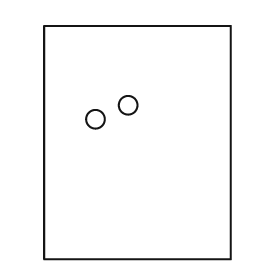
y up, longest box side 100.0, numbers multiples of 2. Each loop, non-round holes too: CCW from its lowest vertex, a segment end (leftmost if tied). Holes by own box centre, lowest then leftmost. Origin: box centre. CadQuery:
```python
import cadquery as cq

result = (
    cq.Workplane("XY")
    .moveTo(-40.0, -50.0)
    .lineTo(40.0, -50.0)
    .lineTo(40.0, 50.0)
    .lineTo(-40.0, 50.0)
    .close()
    .moveTo(-18.0, 10.0)
    .circle(4.0)
    .moveTo(-4.0, 16.0)
    .circle(4.0)
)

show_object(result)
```